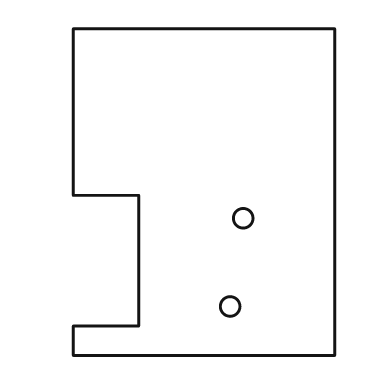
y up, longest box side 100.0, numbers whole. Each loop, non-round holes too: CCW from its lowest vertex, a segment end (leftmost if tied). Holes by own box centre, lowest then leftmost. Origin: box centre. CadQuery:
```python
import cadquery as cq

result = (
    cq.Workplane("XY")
    .moveTo(-40.0, -50.0)
    .lineTo(40.0, -50.0)
    .lineTo(40.0, 50.0)
    .lineTo(-40.0, 50.0)
    .lineTo(-40.0, -1.0)
    .lineTo(-20.0, -1.0)
    .lineTo(-20.0, -41.0)
    .lineTo(-40.0, -41.0)
    .close()
    .moveTo(8.0, -35.0)
    .circle(3.0)
    .moveTo(12.0, -8.0)
    .circle(3.0)
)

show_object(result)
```